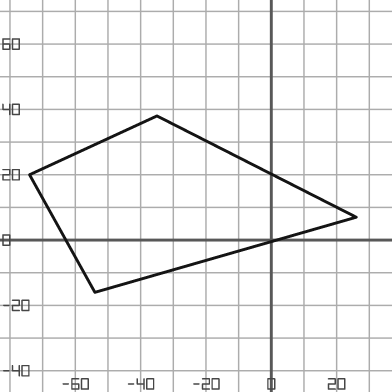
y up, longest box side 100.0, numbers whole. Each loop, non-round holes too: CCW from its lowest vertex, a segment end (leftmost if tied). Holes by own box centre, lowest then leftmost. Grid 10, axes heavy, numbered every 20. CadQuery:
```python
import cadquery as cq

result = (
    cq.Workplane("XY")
    .moveTo(-54.0, -16.0)
    .lineTo(26.0, 7.0)
    .lineTo(-35.0, 38.0)
    .lineTo(-74.0, 20.0)
    .close()
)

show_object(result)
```